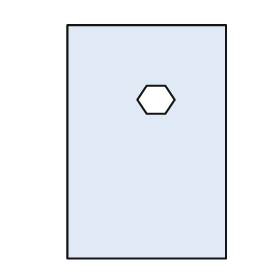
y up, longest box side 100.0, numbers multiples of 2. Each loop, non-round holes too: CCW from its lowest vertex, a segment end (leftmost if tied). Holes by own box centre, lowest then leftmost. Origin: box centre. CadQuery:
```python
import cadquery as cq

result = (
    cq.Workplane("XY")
    .moveTo(-34.0, -50.0)
    .lineTo(34.0, -50.0)
    .lineTo(34.0, 50.0)
    .lineTo(-34.0, 50.0)
    .close()
    .moveTo(0.0, 12.0)
    .lineTo(8.0, 12.0)
    .lineTo(12.0, 18.0)
    .lineTo(8.0, 24.0)
    .lineTo(0.0, 24.0)
    .lineTo(-4.0, 18.0)
    .close()
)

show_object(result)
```